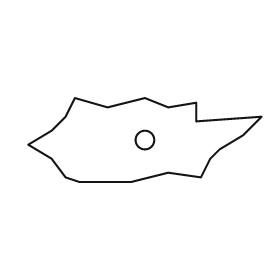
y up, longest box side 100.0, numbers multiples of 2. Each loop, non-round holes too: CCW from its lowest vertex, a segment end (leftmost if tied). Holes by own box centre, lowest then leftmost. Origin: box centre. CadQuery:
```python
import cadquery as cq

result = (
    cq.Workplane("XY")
    .moveTo(-28.0, -18.0)
    .lineTo(-6.0, -18.0)
    .lineTo(10.0, -14.0)
    .lineTo(24.0, -16.0)
    .lineTo(28.0, -8.0)
    .lineTo(32.0, -4.0)
    .lineTo(42.0, 2.0)
    .lineTo(50.0, 10.0)
    .lineTo(22.0, 8.0)
    .lineTo(22.0, 16.0)
    .lineTo(10.0, 14.0)
    .lineTo(0.0, 18.0)
    .lineTo(-16.0, 14.0)
    .lineTo(-30.0, 18.0)
    .lineTo(-34.0, 10.0)
    .lineTo(-40.0, 4.0)
    .lineTo(-50.0, -2.0)
    .lineTo(-40.0, -8.0)
    .lineTo(-34.0, -16.0)
    .close()
    .moveTo(0.0, 0.0)
    .circle(4.0)
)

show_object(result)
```